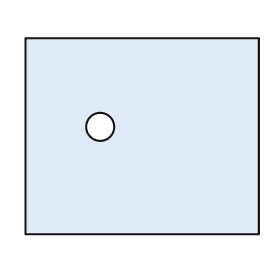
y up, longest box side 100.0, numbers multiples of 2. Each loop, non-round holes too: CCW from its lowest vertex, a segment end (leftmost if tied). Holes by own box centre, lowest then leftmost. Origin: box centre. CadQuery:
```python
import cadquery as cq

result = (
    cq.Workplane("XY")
    .moveTo(-50.0, -42.0)
    .lineTo(50.0, -42.0)
    .lineTo(50.0, 42.0)
    .lineTo(-50.0, 42.0)
    .close()
    .moveTo(-18.0, 4.0)
    .circle(6.0)
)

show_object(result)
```